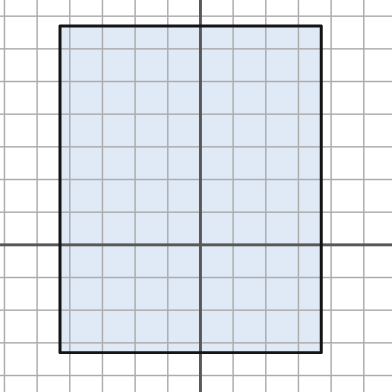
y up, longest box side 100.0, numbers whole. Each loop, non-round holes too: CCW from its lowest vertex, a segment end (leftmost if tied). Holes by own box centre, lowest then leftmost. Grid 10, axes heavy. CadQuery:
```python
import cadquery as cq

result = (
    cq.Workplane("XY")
    .moveTo(-43.0, -33.0)
    .lineTo(37.0, -33.0)
    .lineTo(37.0, 67.0)
    .lineTo(-43.0, 67.0)
    .close()
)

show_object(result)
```